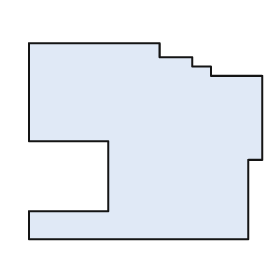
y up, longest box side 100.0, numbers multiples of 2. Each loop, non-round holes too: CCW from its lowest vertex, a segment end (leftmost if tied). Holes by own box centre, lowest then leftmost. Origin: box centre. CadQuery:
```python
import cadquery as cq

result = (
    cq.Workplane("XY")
    .moveTo(-50.0, -42.0)
    .lineTo(44.0, -42.0)
    .lineTo(44.0, -8.0)
    .lineTo(50.0, -8.0)
    .lineTo(50.0, 28.0)
    .lineTo(28.0, 28.0)
    .lineTo(28.0, 32.0)
    .lineTo(20.0, 32.0)
    .lineTo(20.0, 36.0)
    .lineTo(6.0, 36.0)
    .lineTo(6.0, 42.0)
    .lineTo(-50.0, 42.0)
    .lineTo(-50.0, 0.0)
    .lineTo(-16.0, 0.0)
    .lineTo(-16.0, -30.0)
    .lineTo(-50.0, -30.0)
    .close()
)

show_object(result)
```